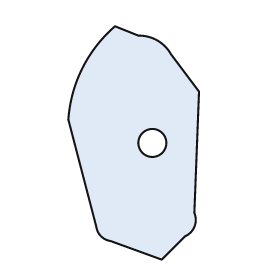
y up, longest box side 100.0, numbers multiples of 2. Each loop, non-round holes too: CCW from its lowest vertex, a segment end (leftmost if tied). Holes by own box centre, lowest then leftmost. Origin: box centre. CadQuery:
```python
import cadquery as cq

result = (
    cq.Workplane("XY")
    .moveTo(12.0, -50.0)
    .lineTo(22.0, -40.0)
    .threePointArc((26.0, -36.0), (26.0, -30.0))
    .lineTo(28.0, 22.0)
    .lineTo(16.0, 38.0)
    .threePointArc((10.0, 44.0), (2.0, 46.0))
    .lineTo(-8.0, 50.0)
    .threePointArc((-22.0, 32.0), (-28.0, 10.0))
    .lineTo(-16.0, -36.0)
    .threePointArc((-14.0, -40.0), (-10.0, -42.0))
    .close()
    .moveTo(8.0, 0.0)
    .circle(6.0)
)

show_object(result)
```